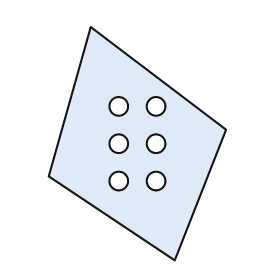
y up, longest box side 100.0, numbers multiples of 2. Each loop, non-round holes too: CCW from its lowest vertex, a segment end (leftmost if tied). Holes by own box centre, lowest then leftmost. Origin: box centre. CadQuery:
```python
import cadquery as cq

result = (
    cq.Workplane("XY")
    .moveTo(16.0, -50.0)
    .lineTo(38.0, 6.0)
    .lineTo(-20.0, 50.0)
    .lineTo(-38.0, -14.0)
    .close()
    .moveTo(-8.0, -16.0)
    .circle(4.0)
    .moveTo(8.0, -16.0)
    .circle(4.0)
    .moveTo(-8.0, 0.0)
    .circle(4.0)
    .moveTo(8.0, 0.0)
    .circle(4.0)
    .moveTo(-8.0, 16.0)
    .circle(4.0)
    .moveTo(8.0, 16.0)
    .circle(4.0)
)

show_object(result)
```